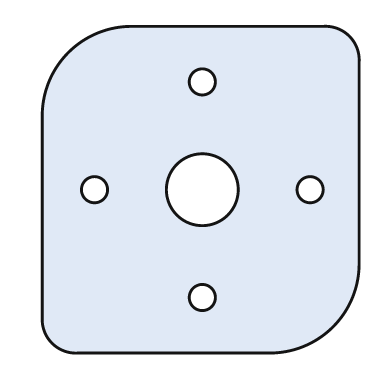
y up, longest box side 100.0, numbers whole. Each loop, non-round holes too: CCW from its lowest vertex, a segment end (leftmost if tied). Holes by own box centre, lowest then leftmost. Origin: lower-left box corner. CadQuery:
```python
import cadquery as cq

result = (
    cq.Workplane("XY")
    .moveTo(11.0, 0.0)
    .lineTo(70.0, 0.0)
    .threePointArc((89.0, 8.0), (97.0, 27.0))
    .lineTo(97.0, 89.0)
    .threePointArc((94.0, 97.0), (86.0, 100.0))
    .lineTo(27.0, 100.0)
    .threePointArc((8.0, 92.0), (0.0, 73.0))
    .lineTo(0.0, 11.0)
    .threePointArc((3.0, 3.0), (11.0, 0.0))
    .close()
    .moveTo(49.0, 17.0)
    .circle(4.0)
    .moveTo(16.0, 50.0)
    .circle(4.0)
    .moveTo(49.0, 50.0)
    .circle(11.0)
    .moveTo(82.0, 50.0)
    .circle(4.0)
    .moveTo(49.0, 83.0)
    .circle(4.0)
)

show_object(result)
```